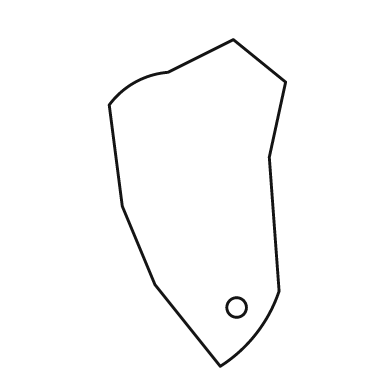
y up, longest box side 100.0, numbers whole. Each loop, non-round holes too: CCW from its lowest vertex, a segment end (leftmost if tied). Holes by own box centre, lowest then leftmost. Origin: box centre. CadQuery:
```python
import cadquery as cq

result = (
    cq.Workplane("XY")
    .moveTo(7.0, -50.0)
    .threePointArc((18.0, -40.0), (25.0, -27.0))
    .lineTo(22.0, 14.0)
    .lineTo(27.0, 37.0)
    .lineTo(11.0, 50.0)
    .lineTo(-9.0, 40.0)
    .threePointArc((-19.0, 37.0), (-27.0, 30.0))
    .lineTo(-23.0, -1.0)
    .lineTo(-13.0, -25.0)
    .close()
    .moveTo(12.0, -32.0)
    .circle(3.0)
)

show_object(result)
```